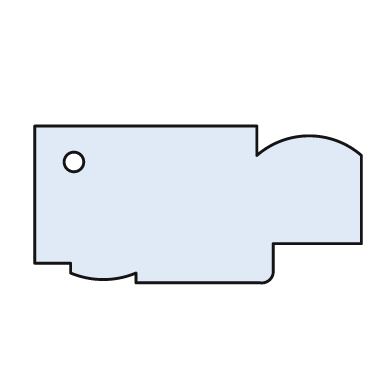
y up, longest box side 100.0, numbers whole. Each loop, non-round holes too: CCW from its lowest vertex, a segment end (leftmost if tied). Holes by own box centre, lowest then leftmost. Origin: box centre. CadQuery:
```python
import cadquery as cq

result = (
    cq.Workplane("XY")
    .moveTo(-19.0, -24.0)
    .lineTo(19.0, -24.0)
    .threePointArc((22.0, -23.0), (23.0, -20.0))
    .lineTo(23.0, -12.0)
    .lineTo(50.0, -12.0)
    .lineTo(50.0, 15.0)
    .threePointArc((34.0, 21.0), (18.0, 15.0))
    .lineTo(18.0, 24.0)
    .lineTo(-50.0, 24.0)
    .lineTo(-50.0, -18.0)
    .lineTo(-39.0, -18.0)
    .lineTo(-39.0, -21.0)
    .threePointArc((-29.0, -23.0), (-19.0, -21.0))
    .close()
    .moveTo(-38.0, 13.0)
    .circle(3.0)
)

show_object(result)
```